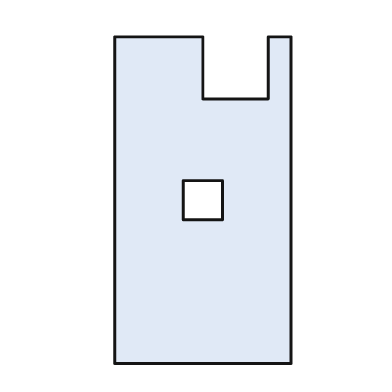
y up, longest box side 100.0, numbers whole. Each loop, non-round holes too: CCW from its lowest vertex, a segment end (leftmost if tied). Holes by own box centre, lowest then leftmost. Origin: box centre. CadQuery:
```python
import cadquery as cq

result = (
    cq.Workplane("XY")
    .moveTo(-27.0, -50.0)
    .lineTo(27.0, -50.0)
    .lineTo(27.0, 50.0)
    .lineTo(20.0, 50.0)
    .lineTo(20.0, 31.0)
    .lineTo(0.0, 31.0)
    .lineTo(0.0, 50.0)
    .lineTo(-27.0, 50.0)
    .close()
    .moveTo(-6.0, -6.0)
    .lineTo(6.0, -6.0)
    .lineTo(6.0, 6.0)
    .lineTo(-6.0, 6.0)
    .close()
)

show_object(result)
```